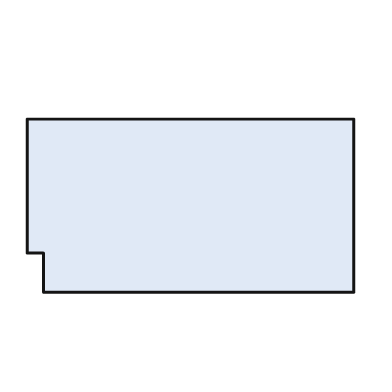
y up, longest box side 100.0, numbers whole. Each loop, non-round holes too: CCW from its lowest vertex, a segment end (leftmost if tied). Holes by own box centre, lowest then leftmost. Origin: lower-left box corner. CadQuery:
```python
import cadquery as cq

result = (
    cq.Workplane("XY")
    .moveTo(5.0, 0.0)
    .lineTo(100.0, 0.0)
    .lineTo(100.0, 53.0)
    .lineTo(0.0, 53.0)
    .lineTo(0.0, 12.0)
    .lineTo(5.0, 12.0)
    .close()
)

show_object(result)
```